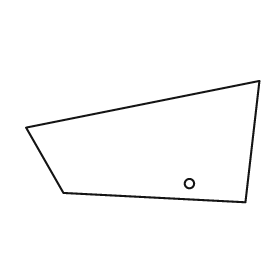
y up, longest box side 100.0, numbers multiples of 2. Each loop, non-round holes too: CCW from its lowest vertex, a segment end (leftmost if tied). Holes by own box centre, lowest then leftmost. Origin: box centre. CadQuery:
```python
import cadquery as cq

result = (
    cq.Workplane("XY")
    .moveTo(44.0, -26.0)
    .lineTo(50.0, 26.0)
    .lineTo(-50.0, 6.0)
    .lineTo(-34.0, -22.0)
    .close()
    .moveTo(20.0, -18.0)
    .circle(2.0)
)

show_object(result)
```